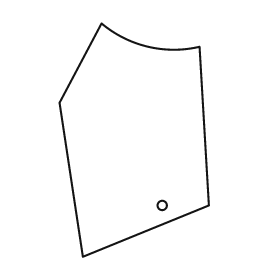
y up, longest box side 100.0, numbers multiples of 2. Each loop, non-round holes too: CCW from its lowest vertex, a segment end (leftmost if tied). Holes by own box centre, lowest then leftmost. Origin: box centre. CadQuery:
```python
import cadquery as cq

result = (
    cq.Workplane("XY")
    .moveTo(-22.0, -50.0)
    .lineTo(32.0, -28.0)
    .lineTo(28.0, 40.0)
    .threePointArc((6.0, 40.0), (-14.0, 50.0))
    .lineTo(-32.0, 16.0)
    .close()
    .moveTo(12.0, -28.0)
    .circle(2.0)
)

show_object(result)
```